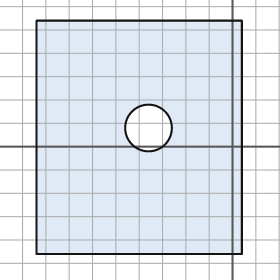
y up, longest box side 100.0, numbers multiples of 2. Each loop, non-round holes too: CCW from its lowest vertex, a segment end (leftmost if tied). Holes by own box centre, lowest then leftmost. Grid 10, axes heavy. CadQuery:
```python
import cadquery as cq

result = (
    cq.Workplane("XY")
    .moveTo(-84.0, -46.0)
    .lineTo(4.0, -46.0)
    .lineTo(4.0, 54.0)
    .lineTo(-84.0, 54.0)
    .close()
    .moveTo(-36.0, 8.0)
    .circle(10.0)
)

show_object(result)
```